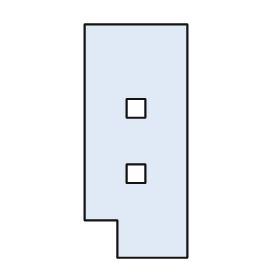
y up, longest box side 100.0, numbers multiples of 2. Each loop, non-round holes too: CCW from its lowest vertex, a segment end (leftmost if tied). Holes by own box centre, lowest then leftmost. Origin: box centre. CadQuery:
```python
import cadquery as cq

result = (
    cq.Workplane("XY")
    .moveTo(-8.0, -50.0)
    .lineTo(22.0, -50.0)
    .lineTo(22.0, 50.0)
    .lineTo(-22.0, 50.0)
    .lineTo(-22.0, -34.0)
    .lineTo(-8.0, -34.0)
    .close()
    .moveTo(-4.0, -18.0)
    .lineTo(4.0, -18.0)
    .lineTo(4.0, -10.0)
    .lineTo(-4.0, -10.0)
    .close()
    .moveTo(-4.0, 10.0)
    .lineTo(4.0, 10.0)
    .lineTo(4.0, 18.0)
    .lineTo(-4.0, 18.0)
    .close()
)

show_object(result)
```